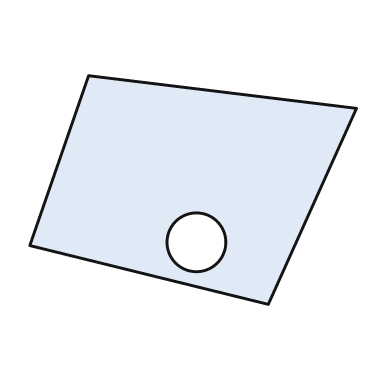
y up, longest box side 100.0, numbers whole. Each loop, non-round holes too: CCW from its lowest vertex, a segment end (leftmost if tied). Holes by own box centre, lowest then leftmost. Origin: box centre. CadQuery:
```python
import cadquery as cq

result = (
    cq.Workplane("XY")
    .moveTo(23.0, -35.0)
    .lineTo(50.0, 25.0)
    .lineTo(-32.0, 35.0)
    .lineTo(-50.0, -17.0)
    .close()
    .moveTo(1.0, -16.0)
    .circle(9.0)
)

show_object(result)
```